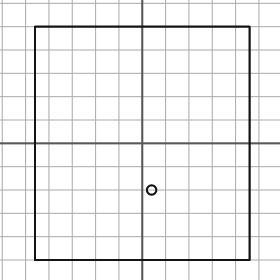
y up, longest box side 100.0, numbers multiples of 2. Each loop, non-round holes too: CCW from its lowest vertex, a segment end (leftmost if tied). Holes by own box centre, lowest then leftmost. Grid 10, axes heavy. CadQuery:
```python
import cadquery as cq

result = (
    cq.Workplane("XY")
    .moveTo(-46.0, -50.0)
    .lineTo(46.0, -50.0)
    .lineTo(46.0, 50.0)
    .lineTo(-46.0, 50.0)
    .close()
    .moveTo(4.0, -20.0)
    .circle(2.0)
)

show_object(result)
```